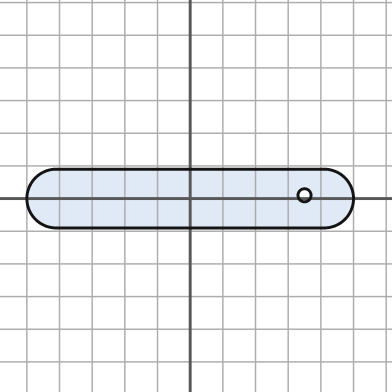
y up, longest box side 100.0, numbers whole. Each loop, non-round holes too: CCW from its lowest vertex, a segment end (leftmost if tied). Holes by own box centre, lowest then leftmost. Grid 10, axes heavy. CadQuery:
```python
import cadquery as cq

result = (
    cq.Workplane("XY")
    .moveTo(-41.0, -9.0)
    .lineTo(41.0, -9.0)
    .threePointArc((50.0, 0.0), (41.0, 9.0))
    .lineTo(-41.0, 9.0)
    .threePointArc((-50.0, 0.0), (-41.0, -9.0))
    .close()
    .moveTo(35.0, 1.0)
    .circle(2.0)
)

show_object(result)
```